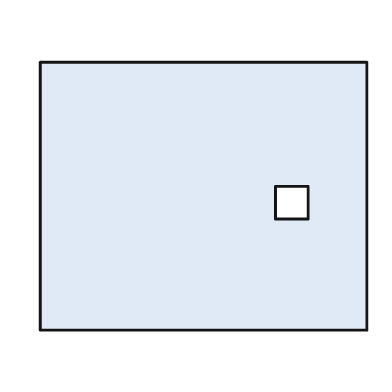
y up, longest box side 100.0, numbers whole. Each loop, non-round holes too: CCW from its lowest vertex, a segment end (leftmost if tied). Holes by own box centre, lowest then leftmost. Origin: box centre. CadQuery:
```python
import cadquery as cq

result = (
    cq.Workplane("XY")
    .moveTo(-50.0, -41.0)
    .lineTo(50.0, -41.0)
    .lineTo(50.0, 41.0)
    .lineTo(-50.0, 41.0)
    .close()
    .moveTo(22.0, -7.0)
    .lineTo(32.0, -7.0)
    .lineTo(32.0, 3.0)
    .lineTo(22.0, 3.0)
    .close()
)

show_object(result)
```